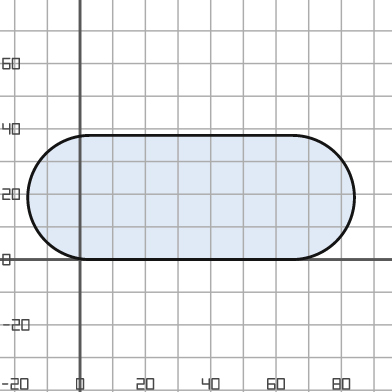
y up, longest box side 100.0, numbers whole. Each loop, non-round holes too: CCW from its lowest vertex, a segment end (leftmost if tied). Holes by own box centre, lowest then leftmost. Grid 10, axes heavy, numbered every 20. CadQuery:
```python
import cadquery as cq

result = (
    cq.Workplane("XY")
    .moveTo(3.0, 0.0)
    .lineTo(65.0, 0.0)
    .threePointArc((84.0, 19.0), (65.0, 38.0))
    .lineTo(3.0, 38.0)
    .threePointArc((-16.0, 19.0), (3.0, 0.0))
    .close()
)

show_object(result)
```